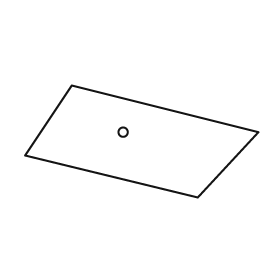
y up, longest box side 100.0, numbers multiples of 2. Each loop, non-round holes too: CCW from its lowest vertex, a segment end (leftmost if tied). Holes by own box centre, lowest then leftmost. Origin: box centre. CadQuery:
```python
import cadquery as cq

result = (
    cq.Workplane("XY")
    .moveTo(24.0, -24.0)
    .lineTo(50.0, 4.0)
    .lineTo(-30.0, 24.0)
    .lineTo(-50.0, -6.0)
    .close()
    .moveTo(-8.0, 4.0)
    .circle(2.0)
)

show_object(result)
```